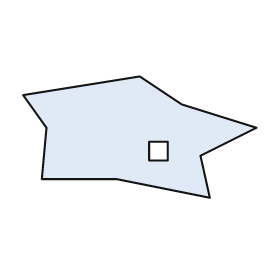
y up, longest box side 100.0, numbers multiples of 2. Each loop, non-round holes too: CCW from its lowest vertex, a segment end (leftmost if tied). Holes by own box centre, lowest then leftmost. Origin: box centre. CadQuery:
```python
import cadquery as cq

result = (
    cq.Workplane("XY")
    .moveTo(30.0, -26.0)
    .lineTo(26.0, -8.0)
    .lineTo(50.0, 4.0)
    .lineTo(18.0, 14.0)
    .lineTo(0.0, 26.0)
    .lineTo(-50.0, 18.0)
    .lineTo(-40.0, 4.0)
    .lineTo(-42.0, -18.0)
    .lineTo(-10.0, -18.0)
    .close()
    .moveTo(4.0, -10.0)
    .lineTo(12.0, -10.0)
    .lineTo(12.0, -2.0)
    .lineTo(4.0, -2.0)
    .close()
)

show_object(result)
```